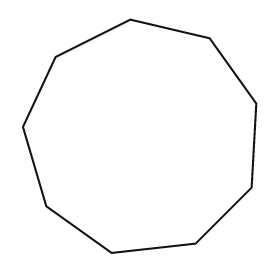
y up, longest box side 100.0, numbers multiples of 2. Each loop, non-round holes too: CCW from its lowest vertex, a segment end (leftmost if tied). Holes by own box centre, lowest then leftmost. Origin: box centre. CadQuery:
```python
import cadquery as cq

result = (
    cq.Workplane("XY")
    .moveTo(-12.0, -50.0)
    .lineTo(24.0, -46.0)
    .lineTo(48.0, -22.0)
    .lineTo(50.0, 14.0)
    .lineTo(30.0, 42.0)
    .lineTo(-4.0, 50.0)
    .lineTo(-36.0, 34.0)
    .lineTo(-50.0, 4.0)
    .lineTo(-40.0, -30.0)
    .close()
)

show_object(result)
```